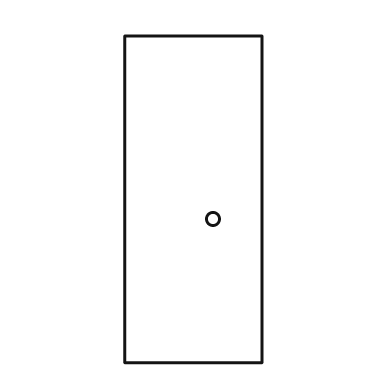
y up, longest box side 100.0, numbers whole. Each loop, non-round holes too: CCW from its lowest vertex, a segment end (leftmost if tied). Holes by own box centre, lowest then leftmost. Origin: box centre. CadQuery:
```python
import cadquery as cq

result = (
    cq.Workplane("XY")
    .moveTo(-21.0, -50.0)
    .lineTo(21.0, -50.0)
    .lineTo(21.0, 50.0)
    .lineTo(-21.0, 50.0)
    .close()
    .moveTo(6.0, -6.0)
    .circle(2.0)
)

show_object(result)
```